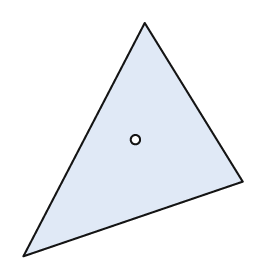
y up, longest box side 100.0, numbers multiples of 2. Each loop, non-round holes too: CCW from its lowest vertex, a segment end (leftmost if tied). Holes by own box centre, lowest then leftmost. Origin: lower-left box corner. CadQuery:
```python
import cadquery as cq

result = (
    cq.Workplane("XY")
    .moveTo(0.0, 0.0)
    .lineTo(94.0, 32.0)
    .lineTo(52.0, 100.0)
    .close()
    .moveTo(48.0, 50.0)
    .circle(2.0)
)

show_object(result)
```